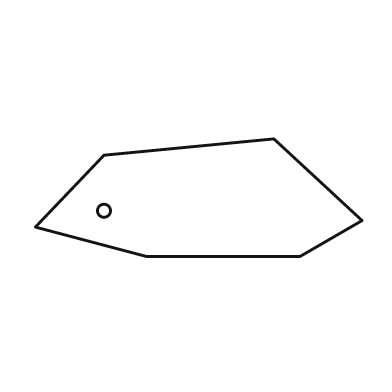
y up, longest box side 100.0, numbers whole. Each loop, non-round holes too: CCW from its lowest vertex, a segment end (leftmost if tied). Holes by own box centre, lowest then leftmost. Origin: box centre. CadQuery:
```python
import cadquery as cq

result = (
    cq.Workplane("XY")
    .moveTo(-16.0, -18.0)
    .lineTo(31.0, -18.0)
    .lineTo(50.0, -7.0)
    .lineTo(23.0, 18.0)
    .lineTo(-29.0, 13.0)
    .lineTo(-50.0, -9.0)
    .close()
    .moveTo(-29.0, -4.0)
    .circle(2.0)
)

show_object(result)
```